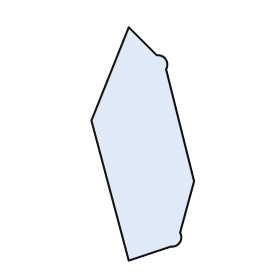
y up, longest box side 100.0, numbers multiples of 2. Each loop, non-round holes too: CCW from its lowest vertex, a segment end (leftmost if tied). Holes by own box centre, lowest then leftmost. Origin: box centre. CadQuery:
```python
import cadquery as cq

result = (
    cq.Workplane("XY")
    .moveTo(-6.0, -50.0)
    .lineTo(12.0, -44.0)
    .threePointArc((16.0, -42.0), (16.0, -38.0))
    .lineTo(22.0, -16.0)
    .lineTo(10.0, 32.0)
    .threePointArc((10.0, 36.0), (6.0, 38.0))
    .lineTo(-6.0, 50.0)
    .lineTo(-22.0, 10.0)
    .close()
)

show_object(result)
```